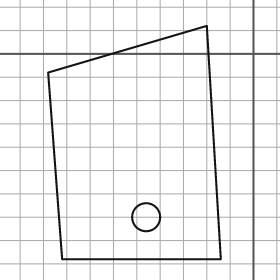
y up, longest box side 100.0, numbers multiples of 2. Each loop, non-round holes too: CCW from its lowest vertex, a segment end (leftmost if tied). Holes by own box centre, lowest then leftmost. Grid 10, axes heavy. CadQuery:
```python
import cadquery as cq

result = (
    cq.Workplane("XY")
    .moveTo(-82.0, -88.0)
    .lineTo(-14.0, -88.0)
    .lineTo(-20.0, 12.0)
    .lineTo(-88.0, -8.0)
    .close()
    .moveTo(-46.0, -70.0)
    .circle(6.0)
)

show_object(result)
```